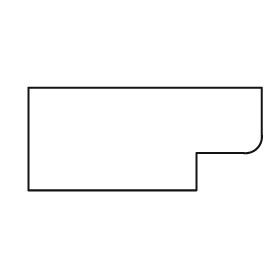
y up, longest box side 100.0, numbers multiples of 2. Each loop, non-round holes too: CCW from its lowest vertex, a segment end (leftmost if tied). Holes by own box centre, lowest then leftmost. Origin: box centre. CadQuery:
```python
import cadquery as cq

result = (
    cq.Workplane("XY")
    .moveTo(-50.0, -22.0)
    .lineTo(22.0, -22.0)
    .lineTo(22.0, -6.0)
    .lineTo(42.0, -6.0)
    .threePointArc((48.0, -4.0), (50.0, 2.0))
    .lineTo(50.0, 22.0)
    .lineTo(-50.0, 22.0)
    .close()
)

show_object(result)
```